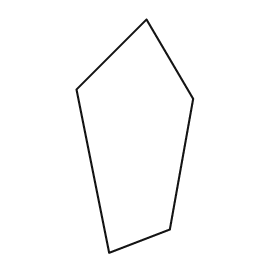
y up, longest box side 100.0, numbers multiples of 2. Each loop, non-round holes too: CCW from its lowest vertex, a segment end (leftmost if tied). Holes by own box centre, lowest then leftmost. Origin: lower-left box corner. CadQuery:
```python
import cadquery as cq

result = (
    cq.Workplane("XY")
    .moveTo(14.0, 0.0)
    .lineTo(40.0, 10.0)
    .lineTo(50.0, 66.0)
    .lineTo(30.0, 100.0)
    .lineTo(0.0, 70.0)
    .close()
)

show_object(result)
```